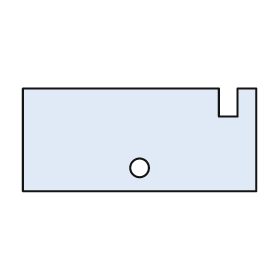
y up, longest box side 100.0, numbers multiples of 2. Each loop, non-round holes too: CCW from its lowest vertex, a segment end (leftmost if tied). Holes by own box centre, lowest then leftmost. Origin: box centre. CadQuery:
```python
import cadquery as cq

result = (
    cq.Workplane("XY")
    .moveTo(-50.0, -22.0)
    .lineTo(50.0, -22.0)
    .lineTo(50.0, 22.0)
    .lineTo(42.0, 22.0)
    .lineTo(42.0, 10.0)
    .lineTo(34.0, 10.0)
    .lineTo(34.0, 22.0)
    .lineTo(-50.0, 22.0)
    .close()
    .moveTo(0.0, -12.0)
    .circle(4.0)
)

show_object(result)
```